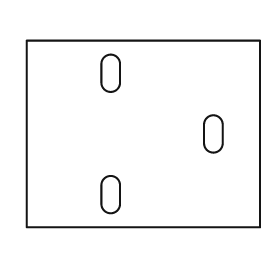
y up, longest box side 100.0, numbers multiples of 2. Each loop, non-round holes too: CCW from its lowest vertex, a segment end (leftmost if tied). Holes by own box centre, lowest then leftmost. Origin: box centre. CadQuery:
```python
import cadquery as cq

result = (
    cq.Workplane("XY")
    .moveTo(-50.0, -40.0)
    .lineTo(50.0, -40.0)
    .lineTo(50.0, 40.0)
    .lineTo(-50.0, 40.0)
    .close()
    .moveTo(-18.0, -30.0)
    .threePointArc((-14.0, -34.0), (-10.0, -30.0))
    .lineTo(-10.0, -22.0)
    .threePointArc((-14.0, -18.0), (-18.0, -22.0))
    .close()
    .moveTo(26.0, -4.0)
    .threePointArc((30.0, -8.0), (34.0, -4.0))
    .lineTo(34.0, 4.0)
    .threePointArc((30.0, 8.0), (26.0, 4.0))
    .close()
    .moveTo(-18.0, 22.0)
    .threePointArc((-14.0, 18.0), (-10.0, 22.0))
    .lineTo(-10.0, 30.0)
    .threePointArc((-14.0, 34.0), (-18.0, 30.0))
    .close()
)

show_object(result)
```